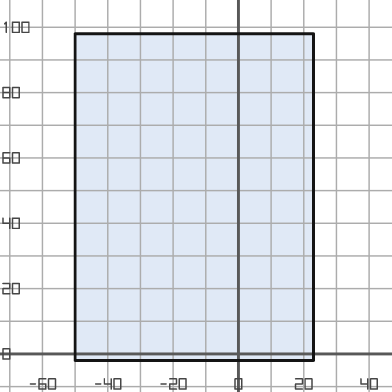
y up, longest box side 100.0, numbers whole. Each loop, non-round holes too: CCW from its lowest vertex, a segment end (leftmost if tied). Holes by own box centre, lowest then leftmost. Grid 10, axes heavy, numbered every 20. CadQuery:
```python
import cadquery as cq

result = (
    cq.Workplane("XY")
    .moveTo(-50.0, -2.0)
    .lineTo(23.0, -2.0)
    .lineTo(23.0, 98.0)
    .lineTo(-50.0, 98.0)
    .close()
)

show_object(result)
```